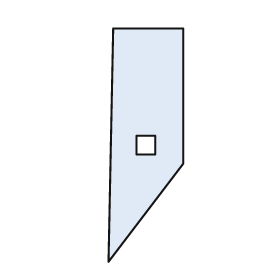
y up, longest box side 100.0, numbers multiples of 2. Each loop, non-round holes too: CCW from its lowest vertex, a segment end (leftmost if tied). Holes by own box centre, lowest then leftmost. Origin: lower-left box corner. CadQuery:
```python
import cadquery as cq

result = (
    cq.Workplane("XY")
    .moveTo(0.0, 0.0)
    .lineTo(32.0, 42.0)
    .lineTo(32.0, 100.0)
    .lineTo(2.0, 100.0)
    .close()
    .moveTo(12.0, 46.0)
    .lineTo(20.0, 46.0)
    .lineTo(20.0, 54.0)
    .lineTo(12.0, 54.0)
    .close()
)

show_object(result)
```